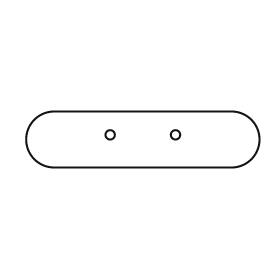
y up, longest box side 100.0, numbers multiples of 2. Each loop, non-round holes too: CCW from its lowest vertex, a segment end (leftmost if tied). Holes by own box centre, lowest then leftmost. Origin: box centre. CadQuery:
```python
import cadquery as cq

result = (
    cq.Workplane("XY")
    .moveTo(-38.0, -12.0)
    .lineTo(38.0, -12.0)
    .threePointArc((50.0, 0.0), (38.0, 12.0))
    .lineTo(-38.0, 12.0)
    .threePointArc((-50.0, 0.0), (-38.0, -12.0))
    .close()
    .moveTo(-14.0, 2.0)
    .circle(2.0)
    .moveTo(14.0, 2.0)
    .circle(2.0)
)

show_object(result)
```